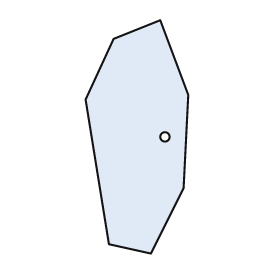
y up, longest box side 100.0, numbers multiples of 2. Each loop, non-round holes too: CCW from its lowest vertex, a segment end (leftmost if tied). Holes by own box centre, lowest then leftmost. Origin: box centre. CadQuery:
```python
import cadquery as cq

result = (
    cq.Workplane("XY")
    .moveTo(6.0, -50.0)
    .lineTo(20.0, -22.0)
    .lineTo(22.0, 18.0)
    .lineTo(10.0, 50.0)
    .lineTo(-10.0, 42.0)
    .lineTo(-22.0, 16.0)
    .lineTo(-12.0, -46.0)
    .close()
    .moveTo(12.0, 0.0)
    .circle(2.0)
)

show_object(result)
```